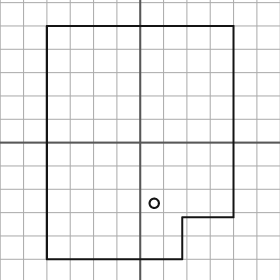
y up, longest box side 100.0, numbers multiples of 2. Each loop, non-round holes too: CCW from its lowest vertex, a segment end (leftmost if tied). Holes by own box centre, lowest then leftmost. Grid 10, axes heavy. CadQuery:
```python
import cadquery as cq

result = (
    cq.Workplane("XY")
    .moveTo(-40.0, -50.0)
    .lineTo(18.0, -50.0)
    .lineTo(18.0, -32.0)
    .lineTo(40.0, -32.0)
    .lineTo(40.0, 50.0)
    .lineTo(-40.0, 50.0)
    .close()
    .moveTo(6.0, -26.0)
    .circle(2.0)
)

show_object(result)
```